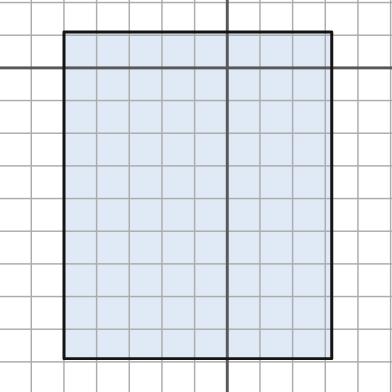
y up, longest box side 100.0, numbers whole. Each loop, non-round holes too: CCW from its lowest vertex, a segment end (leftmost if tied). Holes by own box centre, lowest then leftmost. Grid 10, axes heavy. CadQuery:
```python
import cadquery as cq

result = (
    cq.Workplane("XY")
    .moveTo(-50.0, -89.0)
    .lineTo(32.0, -89.0)
    .lineTo(32.0, 11.0)
    .lineTo(-50.0, 11.0)
    .close()
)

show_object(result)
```